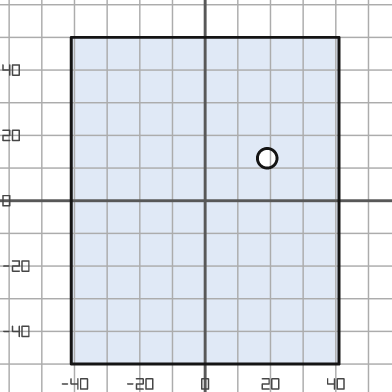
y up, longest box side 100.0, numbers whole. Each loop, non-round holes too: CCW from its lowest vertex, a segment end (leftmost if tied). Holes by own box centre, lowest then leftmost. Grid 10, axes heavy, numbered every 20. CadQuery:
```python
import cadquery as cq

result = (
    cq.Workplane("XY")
    .moveTo(-41.0, -50.0)
    .lineTo(41.0, -50.0)
    .lineTo(41.0, 50.0)
    .lineTo(-41.0, 50.0)
    .close()
    .moveTo(19.0, 13.0)
    .circle(3.0)
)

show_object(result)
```